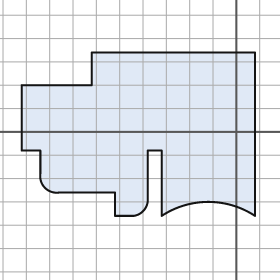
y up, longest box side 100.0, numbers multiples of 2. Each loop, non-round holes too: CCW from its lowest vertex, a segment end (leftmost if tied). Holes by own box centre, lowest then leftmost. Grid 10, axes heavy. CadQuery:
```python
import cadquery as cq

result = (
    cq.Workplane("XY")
    .moveTo(-52.0, -36.0)
    .lineTo(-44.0, -36.0)
    .threePointArc((-40.0, -34.0), (-38.0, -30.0))
    .lineTo(-38.0, -8.0)
    .lineTo(-32.0, -8.0)
    .lineTo(-32.0, -36.0)
    .threePointArc((-12.0, -30.0), (8.0, -36.0))
    .lineTo(8.0, 34.0)
    .lineTo(-62.0, 34.0)
    .lineTo(-62.0, 20.0)
    .lineTo(-92.0, 20.0)
    .lineTo(-92.0, -8.0)
    .lineTo(-84.0, -8.0)
    .lineTo(-84.0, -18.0)
    .threePointArc((-82.0, -24.0), (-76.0, -26.0))
    .lineTo(-52.0, -26.0)
    .close()
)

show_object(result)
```